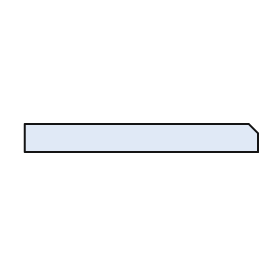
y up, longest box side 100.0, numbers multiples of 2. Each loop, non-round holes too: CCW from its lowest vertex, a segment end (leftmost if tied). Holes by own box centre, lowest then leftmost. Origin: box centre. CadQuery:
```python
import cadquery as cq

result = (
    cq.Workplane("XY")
    .moveTo(-50.0, -6.0)
    .lineTo(50.0, -6.0)
    .lineTo(50.0, 2.0)
    .lineTo(46.0, 6.0)
    .lineTo(-50.0, 6.0)
    .close()
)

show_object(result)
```